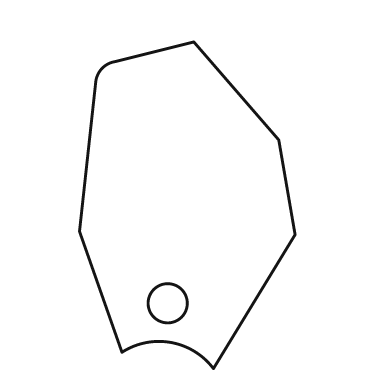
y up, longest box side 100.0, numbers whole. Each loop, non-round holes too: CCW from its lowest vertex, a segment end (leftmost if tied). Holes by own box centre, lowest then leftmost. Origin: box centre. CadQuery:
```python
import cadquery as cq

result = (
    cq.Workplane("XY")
    .moveTo(8.0, -50.0)
    .lineTo(33.0, -9.0)
    .lineTo(28.0, 20.0)
    .lineTo(2.0, 50.0)
    .lineTo(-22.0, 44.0)
    .threePointArc((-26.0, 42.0), (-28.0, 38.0))
    .lineTo(-33.0, -8.0)
    .lineTo(-20.0, -45.0)
    .threePointArc((-5.0, -42.0), (8.0, -50.0))
    .close()
    .moveTo(-6.0, -30.0)
    .circle(6.0)
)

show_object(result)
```